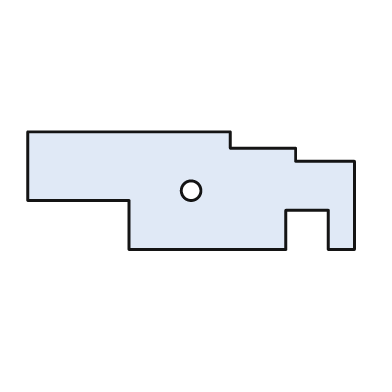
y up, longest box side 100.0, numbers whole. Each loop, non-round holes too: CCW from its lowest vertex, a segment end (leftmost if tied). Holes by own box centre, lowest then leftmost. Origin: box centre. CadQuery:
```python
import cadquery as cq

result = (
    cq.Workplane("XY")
    .moveTo(-19.0, -18.0)
    .lineTo(29.0, -18.0)
    .lineTo(29.0, -6.0)
    .lineTo(42.0, -6.0)
    .lineTo(42.0, -18.0)
    .lineTo(50.0, -18.0)
    .lineTo(50.0, 9.0)
    .lineTo(32.0, 9.0)
    .lineTo(32.0, 13.0)
    .lineTo(12.0, 13.0)
    .lineTo(12.0, 18.0)
    .lineTo(-50.0, 18.0)
    .lineTo(-50.0, -3.0)
    .lineTo(-19.0, -3.0)
    .close()
    .moveTo(0.0, 0.0)
    .circle(3.0)
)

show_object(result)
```